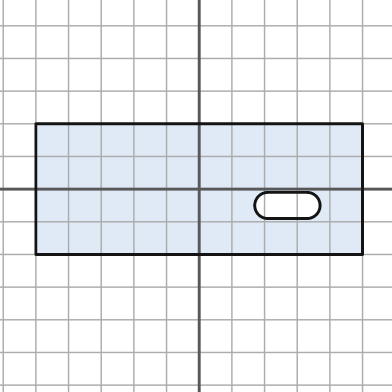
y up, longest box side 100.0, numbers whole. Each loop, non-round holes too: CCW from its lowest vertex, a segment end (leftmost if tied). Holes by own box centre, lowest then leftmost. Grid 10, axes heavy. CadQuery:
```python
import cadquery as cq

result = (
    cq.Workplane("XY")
    .moveTo(-50.0, -20.0)
    .lineTo(50.0, -20.0)
    .lineTo(50.0, 20.0)
    .lineTo(-50.0, 20.0)
    .close()
    .moveTo(21.0, -9.0)
    .lineTo(33.0, -9.0)
    .threePointArc((37.0, -5.0), (33.0, -1.0))
    .lineTo(21.0, -1.0)
    .threePointArc((17.0, -5.0), (21.0, -9.0))
    .close()
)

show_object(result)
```